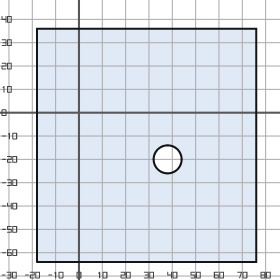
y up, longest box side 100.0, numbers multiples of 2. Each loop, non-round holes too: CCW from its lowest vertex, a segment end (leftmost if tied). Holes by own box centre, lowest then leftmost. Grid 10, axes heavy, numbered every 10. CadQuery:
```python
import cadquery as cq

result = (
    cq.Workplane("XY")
    .moveTo(-18.0, -64.0)
    .lineTo(76.0, -64.0)
    .lineTo(76.0, 36.0)
    .lineTo(-18.0, 36.0)
    .close()
    .moveTo(38.0, -20.0)
    .circle(6.0)
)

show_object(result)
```